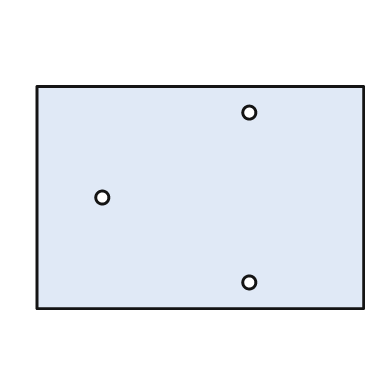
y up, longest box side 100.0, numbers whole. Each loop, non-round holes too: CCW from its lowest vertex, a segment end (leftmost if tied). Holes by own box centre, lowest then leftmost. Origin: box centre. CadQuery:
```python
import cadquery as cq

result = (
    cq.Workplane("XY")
    .moveTo(-50.0, -34.0)
    .lineTo(50.0, -34.0)
    .lineTo(50.0, 34.0)
    .lineTo(-50.0, 34.0)
    .close()
    .moveTo(15.0, -26.0)
    .circle(2.0)
    .moveTo(-30.0, 0.0)
    .circle(2.0)
    .moveTo(15.0, 26.0)
    .circle(2.0)
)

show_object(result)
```